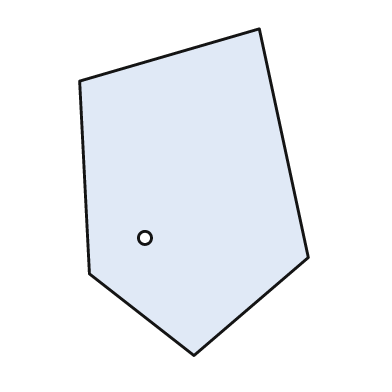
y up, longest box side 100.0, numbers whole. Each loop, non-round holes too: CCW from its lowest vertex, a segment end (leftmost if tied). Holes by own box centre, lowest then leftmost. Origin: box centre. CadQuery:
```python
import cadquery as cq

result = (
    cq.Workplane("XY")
    .moveTo(0.0, -50.0)
    .lineTo(35.0, -20.0)
    .lineTo(20.0, 50.0)
    .lineTo(-35.0, 34.0)
    .lineTo(-32.0, -25.0)
    .close()
    .moveTo(-15.0, -14.0)
    .circle(2.0)
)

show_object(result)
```